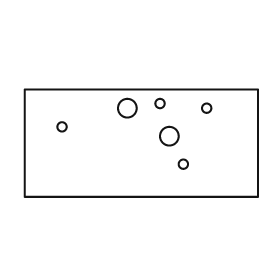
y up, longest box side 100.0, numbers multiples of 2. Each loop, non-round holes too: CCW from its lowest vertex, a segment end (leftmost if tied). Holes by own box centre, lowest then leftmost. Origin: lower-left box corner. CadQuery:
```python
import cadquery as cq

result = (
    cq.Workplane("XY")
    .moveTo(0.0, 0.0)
    .lineTo(100.0, 0.0)
    .lineTo(100.0, 46.0)
    .lineTo(0.0, 46.0)
    .close()
    .moveTo(68.0, 14.0)
    .circle(2.0)
    .moveTo(62.0, 26.0)
    .circle(4.0)
    .moveTo(16.0, 30.0)
    .circle(2.0)
    .moveTo(44.0, 38.0)
    .circle(4.0)
    .moveTo(78.0, 38.0)
    .circle(2.0)
    .moveTo(58.0, 40.0)
    .circle(2.0)
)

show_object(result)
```